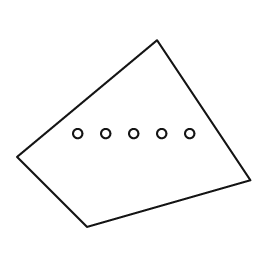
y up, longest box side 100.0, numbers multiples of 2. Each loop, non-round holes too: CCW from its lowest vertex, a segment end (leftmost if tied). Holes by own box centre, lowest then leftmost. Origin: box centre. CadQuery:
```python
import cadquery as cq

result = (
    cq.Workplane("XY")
    .moveTo(-20.0, -40.0)
    .lineTo(50.0, -20.0)
    .lineTo(10.0, 40.0)
    .lineTo(-50.0, -10.0)
    .close()
    .moveTo(-24.0, 0.0)
    .circle(2.0)
    .moveTo(-12.0, 0.0)
    .circle(2.0)
    .moveTo(0.0, 0.0)
    .circle(2.0)
    .moveTo(12.0, 0.0)
    .circle(2.0)
    .moveTo(24.0, 0.0)
    .circle(2.0)
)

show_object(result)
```